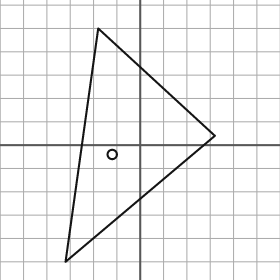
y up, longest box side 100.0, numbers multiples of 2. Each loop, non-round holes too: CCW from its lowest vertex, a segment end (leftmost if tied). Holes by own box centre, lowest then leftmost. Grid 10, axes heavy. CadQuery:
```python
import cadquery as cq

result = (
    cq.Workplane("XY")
    .moveTo(-32.0, -50.0)
    .lineTo(32.0, 4.0)
    .lineTo(-18.0, 50.0)
    .close()
    .moveTo(-12.0, -4.0)
    .circle(2.0)
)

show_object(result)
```